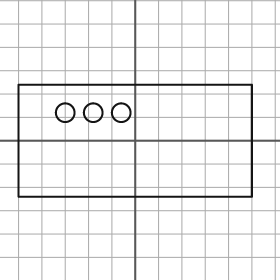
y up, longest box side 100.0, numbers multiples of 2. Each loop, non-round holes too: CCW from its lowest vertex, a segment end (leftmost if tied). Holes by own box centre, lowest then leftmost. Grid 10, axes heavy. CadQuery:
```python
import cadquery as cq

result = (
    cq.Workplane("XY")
    .moveTo(-50.0, -24.0)
    .lineTo(50.0, -24.0)
    .lineTo(50.0, 24.0)
    .lineTo(-50.0, 24.0)
    .close()
    .moveTo(-30.0, 12.0)
    .circle(4.0)
    .moveTo(-18.0, 12.0)
    .circle(4.0)
    .moveTo(-6.0, 12.0)
    .circle(4.0)
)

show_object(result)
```